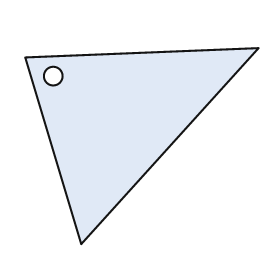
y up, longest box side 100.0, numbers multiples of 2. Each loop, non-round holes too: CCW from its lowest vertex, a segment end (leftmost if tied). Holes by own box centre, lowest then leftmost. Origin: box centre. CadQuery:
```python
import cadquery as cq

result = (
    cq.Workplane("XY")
    .moveTo(-26.0, -42.0)
    .lineTo(50.0, 42.0)
    .lineTo(-50.0, 38.0)
    .close()
    .moveTo(-38.0, 30.0)
    .circle(4.0)
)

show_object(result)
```